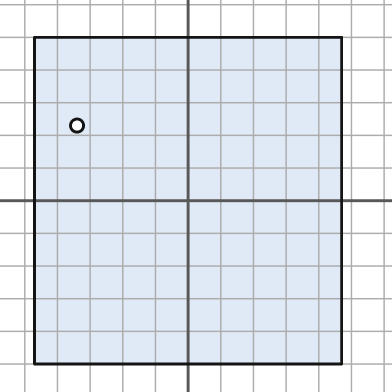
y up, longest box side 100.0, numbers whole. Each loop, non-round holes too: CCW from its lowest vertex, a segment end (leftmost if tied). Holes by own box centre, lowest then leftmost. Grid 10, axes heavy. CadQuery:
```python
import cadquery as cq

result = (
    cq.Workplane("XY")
    .moveTo(-47.0, -50.0)
    .lineTo(47.0, -50.0)
    .lineTo(47.0, 50.0)
    .lineTo(-47.0, 50.0)
    .close()
    .moveTo(-34.0, 23.0)
    .circle(2.0)
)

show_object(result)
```